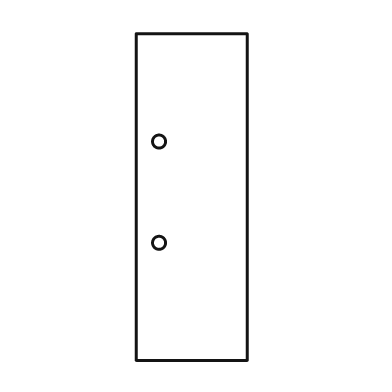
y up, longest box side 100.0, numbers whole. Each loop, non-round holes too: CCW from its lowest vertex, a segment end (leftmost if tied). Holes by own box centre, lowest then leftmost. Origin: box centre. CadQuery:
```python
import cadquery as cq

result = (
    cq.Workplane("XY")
    .moveTo(-17.0, -50.0)
    .lineTo(17.0, -50.0)
    .lineTo(17.0, 50.0)
    .lineTo(-17.0, 50.0)
    .close()
    .moveTo(-10.0, -14.0)
    .circle(2.0)
    .moveTo(-10.0, 17.0)
    .circle(2.0)
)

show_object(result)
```